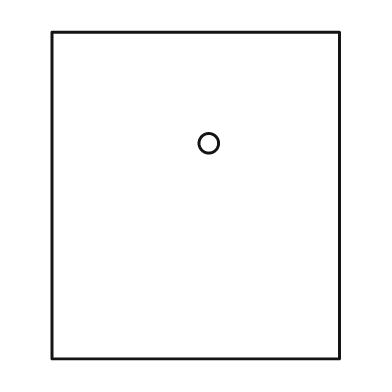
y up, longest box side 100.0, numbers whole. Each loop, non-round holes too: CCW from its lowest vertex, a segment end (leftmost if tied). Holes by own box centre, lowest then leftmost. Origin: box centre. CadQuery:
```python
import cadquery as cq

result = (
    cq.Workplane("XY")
    .moveTo(-44.0, -50.0)
    .lineTo(44.0, -50.0)
    .lineTo(44.0, 50.0)
    .lineTo(-44.0, 50.0)
    .close()
    .moveTo(4.0, 16.0)
    .circle(3.0)
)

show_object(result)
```